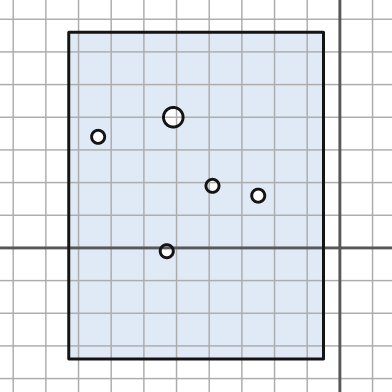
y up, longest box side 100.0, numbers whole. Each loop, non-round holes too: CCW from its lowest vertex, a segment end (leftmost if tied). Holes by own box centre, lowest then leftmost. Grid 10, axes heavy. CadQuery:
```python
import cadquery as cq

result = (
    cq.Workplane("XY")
    .moveTo(-83.0, -34.0)
    .lineTo(-5.0, -34.0)
    .lineTo(-5.0, 66.0)
    .lineTo(-83.0, 66.0)
    .close()
    .moveTo(-53.0, -1.0)
    .circle(2.0)
    .moveTo(-25.0, 16.0)
    .circle(2.0)
    .moveTo(-39.0, 19.0)
    .circle(2.0)
    .moveTo(-74.0, 34.0)
    .circle(2.0)
    .moveTo(-51.0, 40.0)
    .circle(3.0)
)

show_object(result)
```